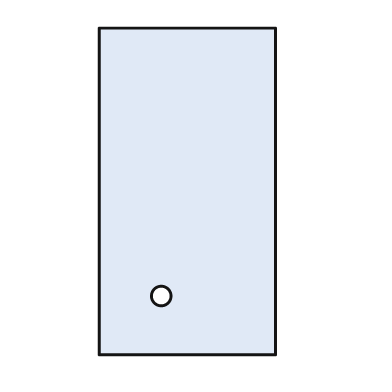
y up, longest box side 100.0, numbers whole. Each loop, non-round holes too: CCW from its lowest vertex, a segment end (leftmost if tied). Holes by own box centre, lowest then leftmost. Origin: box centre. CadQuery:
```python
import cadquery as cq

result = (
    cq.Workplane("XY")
    .moveTo(-27.0, -50.0)
    .lineTo(27.0, -50.0)
    .lineTo(27.0, 50.0)
    .lineTo(-27.0, 50.0)
    .close()
    .moveTo(-8.0, -32.0)
    .circle(3.0)
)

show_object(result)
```